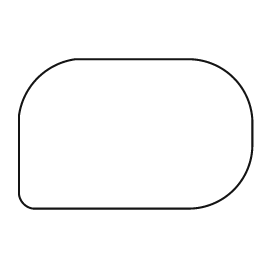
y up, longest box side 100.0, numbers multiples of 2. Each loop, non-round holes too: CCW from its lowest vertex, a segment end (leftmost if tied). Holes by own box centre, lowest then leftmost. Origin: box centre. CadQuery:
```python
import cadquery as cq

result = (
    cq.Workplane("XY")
    .moveTo(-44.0, -32.0)
    .lineTo(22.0, -32.0)
    .threePointArc((42.0, -24.0), (50.0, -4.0))
    .lineTo(50.0, 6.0)
    .threePointArc((42.0, 24.0), (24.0, 32.0))
    .lineTo(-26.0, 32.0)
    .threePointArc((-42.0, 24.0), (-50.0, 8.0))
    .lineTo(-50.0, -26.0)
    .threePointArc((-48.0, -30.0), (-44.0, -32.0))
    .close()
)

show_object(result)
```